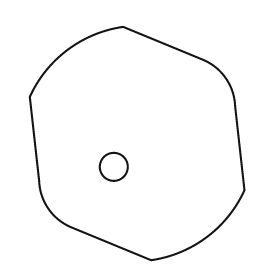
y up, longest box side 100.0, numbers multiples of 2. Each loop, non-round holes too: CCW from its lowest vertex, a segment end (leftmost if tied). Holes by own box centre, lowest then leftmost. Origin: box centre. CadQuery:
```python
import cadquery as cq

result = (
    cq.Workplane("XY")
    .moveTo(6.0, -50.0)
    .threePointArc((30.0, -40.0), (46.0, -20.0))
    .lineTo(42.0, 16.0)
    .threePointArc((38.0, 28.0), (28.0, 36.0))
    .lineTo(-6.0, 50.0)
    .threePointArc((-30.0, 40.0), (-46.0, 20.0))
    .lineTo(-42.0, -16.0)
    .threePointArc((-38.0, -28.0), (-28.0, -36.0))
    .close()
    .moveTo(-10.0, -10.0)
    .circle(6.0)
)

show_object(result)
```